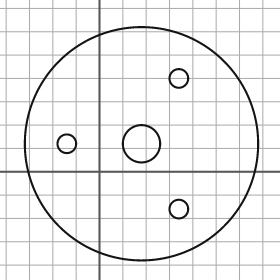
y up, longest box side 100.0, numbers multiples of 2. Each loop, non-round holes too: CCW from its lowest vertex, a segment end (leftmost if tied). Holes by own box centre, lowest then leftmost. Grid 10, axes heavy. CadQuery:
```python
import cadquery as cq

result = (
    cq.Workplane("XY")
    .moveTo(18.0, 12.0)
    .circle(50.0)
    .moveTo(34.0, -16.0)
    .circle(4.0)
    .moveTo(-14.0, 12.0)
    .circle(4.0)
    .moveTo(18.0, 12.0)
    .circle(8.0)
    .moveTo(34.0, 40.0)
    .circle(4.0)
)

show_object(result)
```